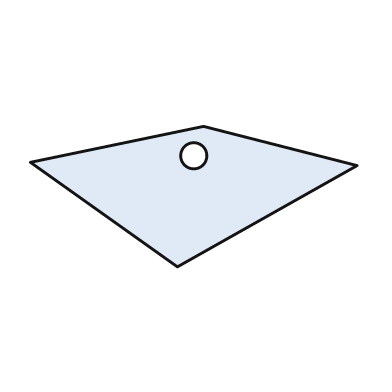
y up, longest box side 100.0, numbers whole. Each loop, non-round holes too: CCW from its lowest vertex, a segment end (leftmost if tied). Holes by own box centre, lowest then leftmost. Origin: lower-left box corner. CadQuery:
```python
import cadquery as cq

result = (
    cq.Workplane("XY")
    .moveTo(45.0, 0.0)
    .lineTo(100.0, 31.0)
    .lineTo(53.0, 43.0)
    .lineTo(0.0, 32.0)
    .close()
    .moveTo(50.0, 34.0)
    .circle(4.0)
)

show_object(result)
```